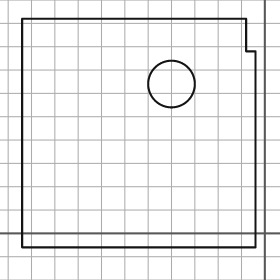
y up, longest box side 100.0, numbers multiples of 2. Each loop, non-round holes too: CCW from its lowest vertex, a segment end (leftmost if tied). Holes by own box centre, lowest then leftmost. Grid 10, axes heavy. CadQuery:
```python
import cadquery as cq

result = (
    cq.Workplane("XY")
    .moveTo(-104.0, -6.0)
    .lineTo(-4.0, -6.0)
    .lineTo(-4.0, 78.0)
    .lineTo(-8.0, 78.0)
    .lineTo(-8.0, 92.0)
    .lineTo(-104.0, 92.0)
    .close()
    .moveTo(-40.0, 64.0)
    .circle(10.0)
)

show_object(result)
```